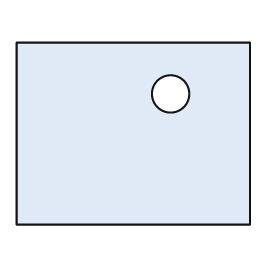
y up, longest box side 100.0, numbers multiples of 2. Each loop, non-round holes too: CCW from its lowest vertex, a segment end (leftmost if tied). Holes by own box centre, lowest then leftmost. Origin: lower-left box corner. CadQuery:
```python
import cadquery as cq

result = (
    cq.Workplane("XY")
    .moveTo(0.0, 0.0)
    .lineTo(100.0, 0.0)
    .lineTo(100.0, 78.0)
    .lineTo(0.0, 78.0)
    .close()
    .moveTo(66.0, 56.0)
    .circle(8.0)
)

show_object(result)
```